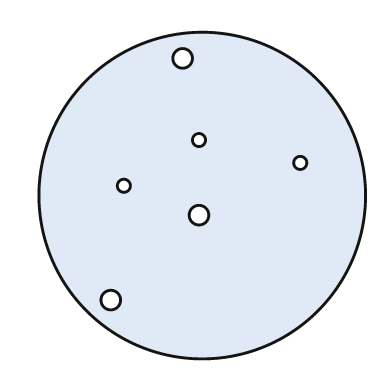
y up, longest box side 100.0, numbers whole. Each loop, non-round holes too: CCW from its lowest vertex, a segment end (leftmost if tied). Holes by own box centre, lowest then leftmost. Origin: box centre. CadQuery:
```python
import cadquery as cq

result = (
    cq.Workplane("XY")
    .moveTo(0.0, 0.0)
    .circle(50.0)
    .moveTo(-28.0, -32.0)
    .circle(3.0)
    .moveTo(-1.0, -6.0)
    .circle(3.0)
    .moveTo(-24.0, 3.0)
    .circle(2.0)
    .moveTo(30.0, 10.0)
    .circle(2.0)
    .moveTo(-1.0, 17.0)
    .circle(2.0)
    .moveTo(-6.0, 42.0)
    .circle(3.0)
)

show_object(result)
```